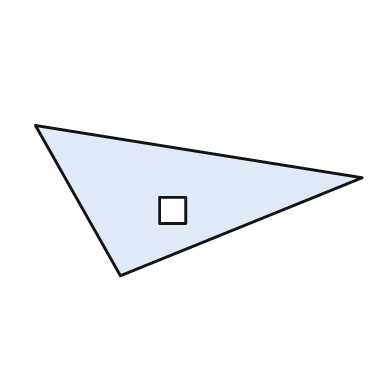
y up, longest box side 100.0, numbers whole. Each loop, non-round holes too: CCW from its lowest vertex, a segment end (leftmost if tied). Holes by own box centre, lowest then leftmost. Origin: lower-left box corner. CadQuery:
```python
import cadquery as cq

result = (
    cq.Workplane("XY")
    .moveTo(26.0, 0.0)
    .lineTo(100.0, 30.0)
    .lineTo(0.0, 46.0)
    .close()
    .moveTo(38.0, 16.0)
    .lineTo(46.0, 16.0)
    .lineTo(46.0, 24.0)
    .lineTo(38.0, 24.0)
    .close()
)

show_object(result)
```